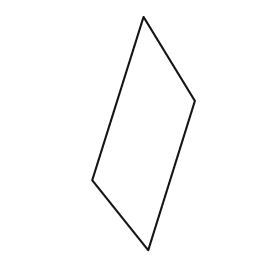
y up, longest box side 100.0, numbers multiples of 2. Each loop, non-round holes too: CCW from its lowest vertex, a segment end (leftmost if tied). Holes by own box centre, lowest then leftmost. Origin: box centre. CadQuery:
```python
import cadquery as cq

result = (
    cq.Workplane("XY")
    .moveTo(2.0, -50.0)
    .lineTo(22.0, 14.0)
    .lineTo(0.0, 50.0)
    .lineTo(-22.0, -20.0)
    .close()
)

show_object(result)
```